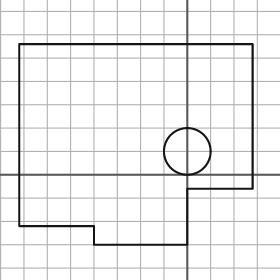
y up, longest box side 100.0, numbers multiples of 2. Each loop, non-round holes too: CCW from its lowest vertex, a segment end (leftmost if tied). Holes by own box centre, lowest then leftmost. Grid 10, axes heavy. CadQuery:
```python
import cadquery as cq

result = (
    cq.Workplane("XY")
    .moveTo(-40.0, -30.0)
    .lineTo(0.0, -30.0)
    .lineTo(0.0, -6.0)
    .lineTo(28.0, -6.0)
    .lineTo(28.0, 56.0)
    .lineTo(-72.0, 56.0)
    .lineTo(-72.0, -22.0)
    .lineTo(-40.0, -22.0)
    .close()
    .moveTo(0.0, 10.0)
    .circle(10.0)
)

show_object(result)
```